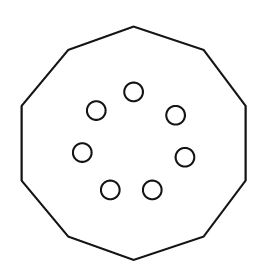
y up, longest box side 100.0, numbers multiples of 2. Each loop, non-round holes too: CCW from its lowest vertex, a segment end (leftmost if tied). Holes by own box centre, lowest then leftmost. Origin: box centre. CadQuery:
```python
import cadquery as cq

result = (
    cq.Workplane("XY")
    .moveTo(0.0, -50.0)
    .lineTo(30.0, -40.0)
    .lineTo(48.0, -16.0)
    .lineTo(48.0, 16.0)
    .lineTo(30.0, 40.0)
    .lineTo(0.0, 50.0)
    .lineTo(-28.0, 40.0)
    .lineTo(-48.0, 16.0)
    .lineTo(-48.0, -16.0)
    .lineTo(-28.0, -40.0)
    .close()
    .moveTo(-10.0, -20.0)
    .circle(4.0)
    .moveTo(8.0, -20.0)
    .circle(4.0)
    .moveTo(22.0, -6.0)
    .circle(4.0)
    .moveTo(-22.0, -4.0)
    .circle(4.0)
    .moveTo(18.0, 12.0)
    .circle(4.0)
    .moveTo(-16.0, 14.0)
    .circle(4.0)
    .moveTo(0.0, 22.0)
    .circle(4.0)
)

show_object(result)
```